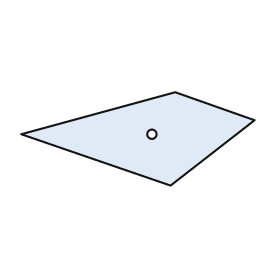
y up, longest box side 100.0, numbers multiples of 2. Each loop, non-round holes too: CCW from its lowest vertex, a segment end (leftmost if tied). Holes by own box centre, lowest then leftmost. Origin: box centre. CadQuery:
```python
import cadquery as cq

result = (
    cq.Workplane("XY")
    .moveTo(14.0, -20.0)
    .lineTo(50.0, 8.0)
    .lineTo(16.0, 20.0)
    .lineTo(-50.0, 2.0)
    .close()
    .moveTo(6.0, 2.0)
    .circle(2.0)
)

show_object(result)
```